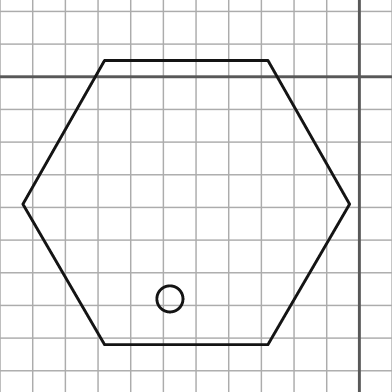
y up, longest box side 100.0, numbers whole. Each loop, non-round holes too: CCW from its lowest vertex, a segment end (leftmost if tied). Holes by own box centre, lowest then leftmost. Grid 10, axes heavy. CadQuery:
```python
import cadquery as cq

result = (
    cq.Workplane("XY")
    .moveTo(-78.0, -82.0)
    .lineTo(-28.0, -82.0)
    .lineTo(-3.0, -39.0)
    .lineTo(-28.0, 5.0)
    .lineTo(-78.0, 5.0)
    .lineTo(-103.0, -39.0)
    .close()
    .moveTo(-58.0, -68.0)
    .circle(4.0)
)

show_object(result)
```